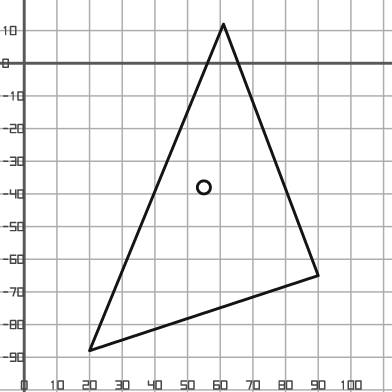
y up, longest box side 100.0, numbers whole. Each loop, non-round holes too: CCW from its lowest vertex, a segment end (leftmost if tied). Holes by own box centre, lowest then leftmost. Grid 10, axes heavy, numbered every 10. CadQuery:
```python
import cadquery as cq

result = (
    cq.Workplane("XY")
    .moveTo(20.0, -88.0)
    .lineTo(90.0, -65.0)
    .lineTo(61.0, 12.0)
    .close()
    .moveTo(55.0, -38.0)
    .circle(2.0)
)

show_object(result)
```